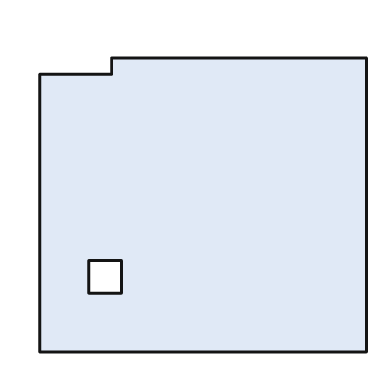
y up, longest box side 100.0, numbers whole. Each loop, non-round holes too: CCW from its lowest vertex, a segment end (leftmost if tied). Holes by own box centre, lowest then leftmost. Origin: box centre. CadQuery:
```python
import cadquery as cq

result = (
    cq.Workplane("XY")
    .moveTo(-50.0, -45.0)
    .lineTo(50.0, -45.0)
    .lineTo(50.0, 45.0)
    .lineTo(-28.0, 45.0)
    .lineTo(-28.0, 40.0)
    .lineTo(-50.0, 40.0)
    .close()
    .moveTo(-35.0, -27.0)
    .lineTo(-25.0, -27.0)
    .lineTo(-25.0, -17.0)
    .lineTo(-35.0, -17.0)
    .close()
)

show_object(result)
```